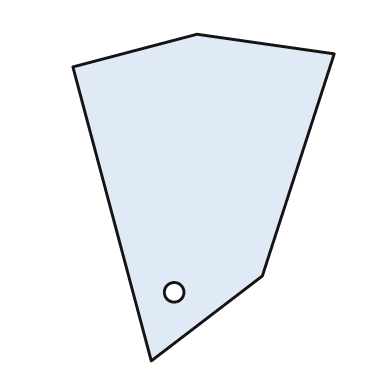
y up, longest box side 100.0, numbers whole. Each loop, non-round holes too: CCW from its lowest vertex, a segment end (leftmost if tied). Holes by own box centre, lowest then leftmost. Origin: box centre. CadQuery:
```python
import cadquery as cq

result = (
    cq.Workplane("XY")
    .moveTo(-16.0, -50.0)
    .lineTo(18.0, -24.0)
    .lineTo(40.0, 44.0)
    .lineTo(-2.0, 50.0)
    .lineTo(-40.0, 40.0)
    .close()
    .moveTo(-9.0, -29.0)
    .circle(3.0)
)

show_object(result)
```